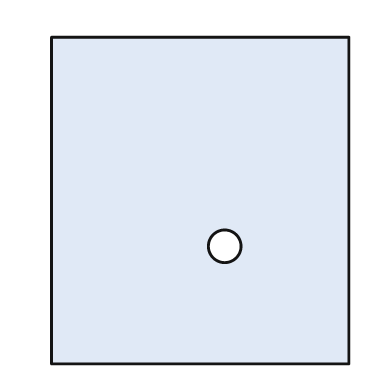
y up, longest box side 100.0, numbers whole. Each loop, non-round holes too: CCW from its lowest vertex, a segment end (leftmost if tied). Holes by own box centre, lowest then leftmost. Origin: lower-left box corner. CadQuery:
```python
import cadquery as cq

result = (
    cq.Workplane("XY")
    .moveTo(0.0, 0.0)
    .lineTo(91.0, 0.0)
    .lineTo(91.0, 100.0)
    .lineTo(0.0, 100.0)
    .close()
    .moveTo(53.0, 36.0)
    .circle(5.0)
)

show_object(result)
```